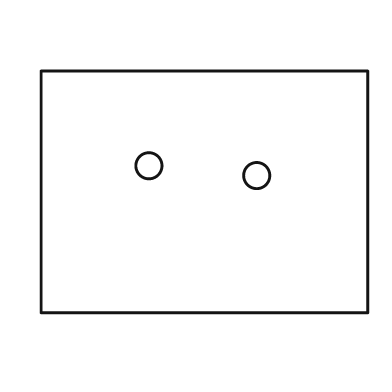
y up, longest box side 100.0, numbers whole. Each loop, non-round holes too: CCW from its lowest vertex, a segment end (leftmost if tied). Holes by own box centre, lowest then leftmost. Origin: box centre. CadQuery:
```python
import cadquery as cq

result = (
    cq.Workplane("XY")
    .moveTo(-50.0, -37.0)
    .lineTo(50.0, -37.0)
    .lineTo(50.0, 37.0)
    .lineTo(-50.0, 37.0)
    .close()
    .moveTo(16.0, 5.0)
    .circle(4.0)
    .moveTo(-17.0, 8.0)
    .circle(4.0)
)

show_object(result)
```